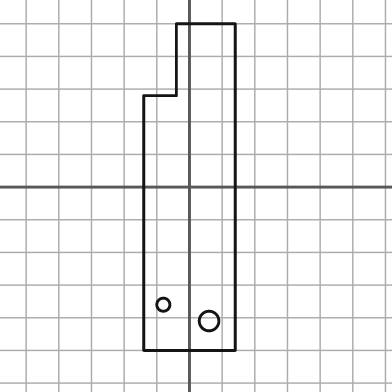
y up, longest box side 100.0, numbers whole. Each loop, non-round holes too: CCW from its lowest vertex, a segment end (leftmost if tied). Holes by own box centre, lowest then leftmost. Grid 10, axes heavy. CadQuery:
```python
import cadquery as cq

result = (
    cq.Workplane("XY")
    .moveTo(-14.0, -50.0)
    .lineTo(14.0, -50.0)
    .lineTo(14.0, 50.0)
    .lineTo(-4.0, 50.0)
    .lineTo(-4.0, 28.0)
    .lineTo(-14.0, 28.0)
    .close()
    .moveTo(6.0, -41.0)
    .circle(3.0)
    .moveTo(-8.0, -36.0)
    .circle(2.0)
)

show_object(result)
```